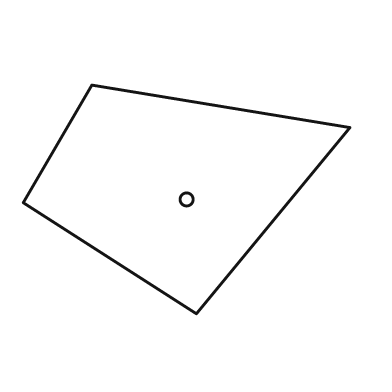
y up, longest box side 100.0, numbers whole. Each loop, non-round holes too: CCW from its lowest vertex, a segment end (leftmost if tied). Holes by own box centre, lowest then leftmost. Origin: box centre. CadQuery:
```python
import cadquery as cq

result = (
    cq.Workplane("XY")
    .moveTo(3.0, -35.0)
    .lineTo(50.0, 22.0)
    .lineTo(-29.0, 35.0)
    .lineTo(-50.0, -1.0)
    .close()
    .moveTo(0.0, 0.0)
    .circle(2.0)
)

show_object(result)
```